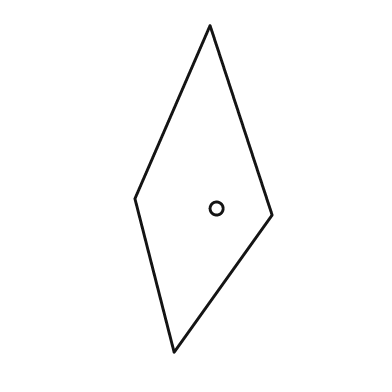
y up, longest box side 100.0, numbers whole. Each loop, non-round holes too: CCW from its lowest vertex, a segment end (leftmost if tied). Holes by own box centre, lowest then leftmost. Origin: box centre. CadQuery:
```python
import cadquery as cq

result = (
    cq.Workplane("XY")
    .moveTo(-9.0, -50.0)
    .lineTo(21.0, -8.0)
    .lineTo(2.0, 50.0)
    .lineTo(-21.0, -3.0)
    .close()
    .moveTo(4.0, -6.0)
    .circle(2.0)
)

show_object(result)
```